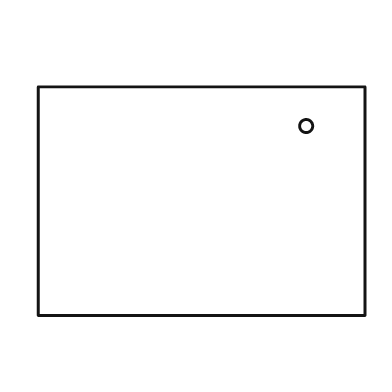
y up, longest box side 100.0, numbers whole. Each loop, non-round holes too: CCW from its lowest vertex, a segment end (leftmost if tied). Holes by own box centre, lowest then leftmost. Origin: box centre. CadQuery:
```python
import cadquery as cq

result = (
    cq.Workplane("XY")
    .moveTo(-50.0, -35.0)
    .lineTo(50.0, -35.0)
    .lineTo(50.0, 35.0)
    .lineTo(-50.0, 35.0)
    .close()
    .moveTo(32.0, 23.0)
    .circle(2.0)
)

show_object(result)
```